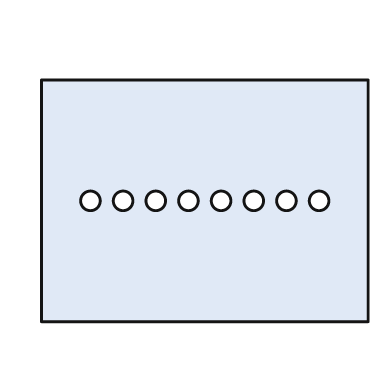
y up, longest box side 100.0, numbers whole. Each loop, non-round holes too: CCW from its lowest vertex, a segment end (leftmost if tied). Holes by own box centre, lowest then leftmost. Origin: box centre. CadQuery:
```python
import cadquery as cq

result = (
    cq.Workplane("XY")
    .moveTo(-50.0, -37.0)
    .lineTo(50.0, -37.0)
    .lineTo(50.0, 37.0)
    .lineTo(-50.0, 37.0)
    .close()
    .moveTo(-35.0, 0.0)
    .circle(3.0)
    .moveTo(-25.0, 0.0)
    .circle(3.0)
    .moveTo(-15.0, 0.0)
    .circle(3.0)
    .moveTo(-5.0, 0.0)
    .circle(3.0)
    .moveTo(5.0, 0.0)
    .circle(3.0)
    .moveTo(15.0, 0.0)
    .circle(3.0)
    .moveTo(25.0, 0.0)
    .circle(3.0)
    .moveTo(35.0, 0.0)
    .circle(3.0)
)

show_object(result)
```